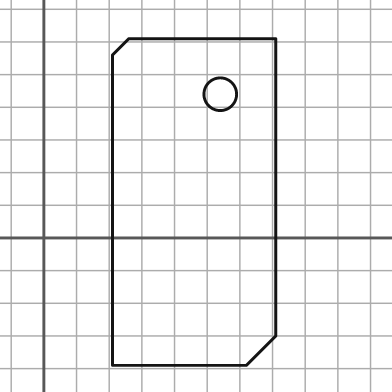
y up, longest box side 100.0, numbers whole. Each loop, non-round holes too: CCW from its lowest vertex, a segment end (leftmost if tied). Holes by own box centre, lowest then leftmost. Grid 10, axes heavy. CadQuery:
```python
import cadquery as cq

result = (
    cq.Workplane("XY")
    .moveTo(21.0, -39.0)
    .lineTo(62.0, -39.0)
    .lineTo(71.0, -30.0)
    .lineTo(71.0, 61.0)
    .lineTo(26.0, 61.0)
    .lineTo(21.0, 56.0)
    .close()
    .moveTo(54.0, 44.0)
    .circle(5.0)
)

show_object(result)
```